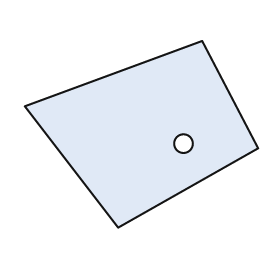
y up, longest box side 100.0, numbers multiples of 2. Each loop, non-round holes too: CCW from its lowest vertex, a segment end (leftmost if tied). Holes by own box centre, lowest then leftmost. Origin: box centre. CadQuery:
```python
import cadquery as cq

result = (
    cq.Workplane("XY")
    .moveTo(-10.0, -40.0)
    .lineTo(50.0, -6.0)
    .lineTo(26.0, 40.0)
    .lineTo(-50.0, 12.0)
    .close()
    .moveTo(18.0, -4.0)
    .circle(4.0)
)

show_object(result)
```